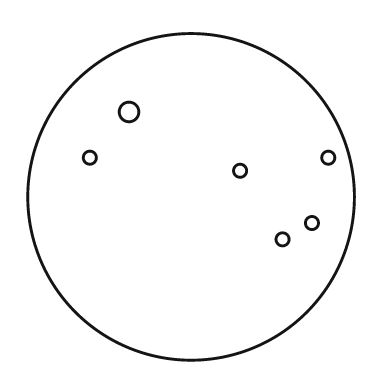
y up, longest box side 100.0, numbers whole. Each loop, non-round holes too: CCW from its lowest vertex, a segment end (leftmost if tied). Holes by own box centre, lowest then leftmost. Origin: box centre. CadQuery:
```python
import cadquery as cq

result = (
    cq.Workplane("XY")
    .moveTo(0.0, 0.0)
    .circle(50.0)
    .moveTo(28.0, -13.0)
    .circle(2.0)
    .moveTo(37.0, -8.0)
    .circle(2.0)
    .moveTo(15.0, 8.0)
    .circle(2.0)
    .moveTo(-31.0, 12.0)
    .circle(2.0)
    .moveTo(42.0, 12.0)
    .circle(2.0)
    .moveTo(-19.0, 26.0)
    .circle(3.0)
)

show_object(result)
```